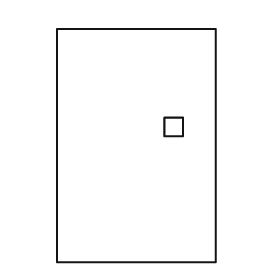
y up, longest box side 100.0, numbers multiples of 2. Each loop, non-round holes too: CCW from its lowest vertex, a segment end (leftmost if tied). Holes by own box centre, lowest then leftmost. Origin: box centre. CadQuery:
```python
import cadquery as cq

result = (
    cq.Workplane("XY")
    .moveTo(-34.0, -50.0)
    .lineTo(34.0, -50.0)
    .lineTo(34.0, 50.0)
    .lineTo(-34.0, 50.0)
    .close()
    .moveTo(12.0, 4.0)
    .lineTo(20.0, 4.0)
    .lineTo(20.0, 12.0)
    .lineTo(12.0, 12.0)
    .close()
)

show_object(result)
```